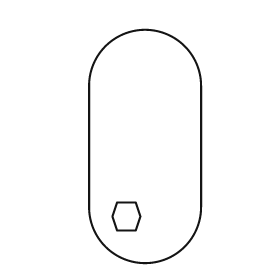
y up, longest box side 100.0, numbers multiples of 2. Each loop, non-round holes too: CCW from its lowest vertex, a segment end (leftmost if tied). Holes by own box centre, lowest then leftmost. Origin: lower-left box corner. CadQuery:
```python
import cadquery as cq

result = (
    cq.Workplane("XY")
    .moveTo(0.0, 24.0)
    .threePointArc((24.0, 0.0), (48.0, 24.0))
    .lineTo(48.0, 76.0)
    .threePointArc((24.0, 100.0), (0.0, 76.0))
    .close()
    .moveTo(12.0, 14.0)
    .lineTo(20.0, 14.0)
    .lineTo(22.0, 20.0)
    .lineTo(20.0, 26.0)
    .lineTo(12.0, 26.0)
    .lineTo(10.0, 20.0)
    .close()
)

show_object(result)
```